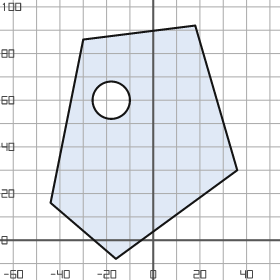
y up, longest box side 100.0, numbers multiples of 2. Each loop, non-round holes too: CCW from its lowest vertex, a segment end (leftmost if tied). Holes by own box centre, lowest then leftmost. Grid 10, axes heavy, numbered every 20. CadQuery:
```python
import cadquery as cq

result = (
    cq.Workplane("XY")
    .moveTo(-16.0, -8.0)
    .lineTo(36.0, 30.0)
    .lineTo(18.0, 92.0)
    .lineTo(-30.0, 86.0)
    .lineTo(-44.0, 16.0)
    .close()
    .moveTo(-18.0, 60.0)
    .circle(8.0)
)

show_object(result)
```